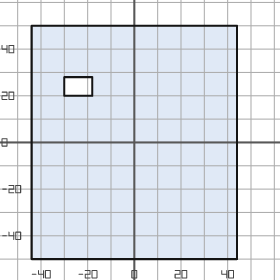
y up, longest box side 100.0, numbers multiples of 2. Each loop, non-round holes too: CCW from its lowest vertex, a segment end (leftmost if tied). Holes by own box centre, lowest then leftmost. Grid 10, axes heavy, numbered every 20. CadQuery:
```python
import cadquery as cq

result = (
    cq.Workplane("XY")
    .moveTo(-44.0, -50.0)
    .lineTo(44.0, -50.0)
    .lineTo(44.0, 50.0)
    .lineTo(-44.0, 50.0)
    .close()
    .moveTo(-30.0, 20.0)
    .lineTo(-18.0, 20.0)
    .lineTo(-18.0, 28.0)
    .lineTo(-30.0, 28.0)
    .close()
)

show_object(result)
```